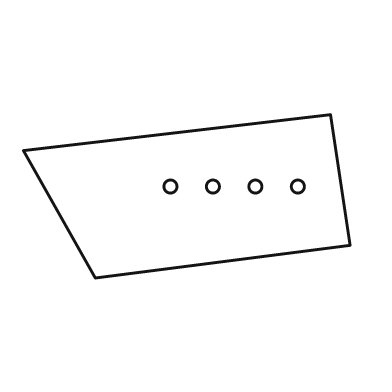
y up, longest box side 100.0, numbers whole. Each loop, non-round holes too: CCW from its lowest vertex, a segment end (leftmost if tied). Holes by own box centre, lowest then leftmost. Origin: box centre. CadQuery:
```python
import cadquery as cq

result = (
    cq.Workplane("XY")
    .moveTo(-28.0, -25.0)
    .lineTo(50.0, -15.0)
    .lineTo(44.0, 25.0)
    .lineTo(-50.0, 14.0)
    .close()
    .moveTo(-5.0, 3.0)
    .circle(2.0)
    .moveTo(8.0, 3.0)
    .circle(2.0)
    .moveTo(21.0, 3.0)
    .circle(2.0)
    .moveTo(34.0, 3.0)
    .circle(2.0)
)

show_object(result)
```